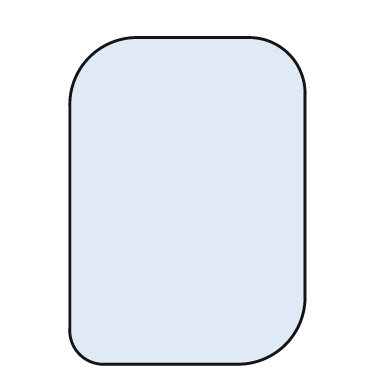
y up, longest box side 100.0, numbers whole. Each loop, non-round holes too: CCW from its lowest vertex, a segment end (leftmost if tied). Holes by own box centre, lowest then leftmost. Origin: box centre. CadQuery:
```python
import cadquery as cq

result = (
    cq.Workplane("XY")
    .moveTo(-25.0, -50.0)
    .lineTo(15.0, -50.0)
    .threePointArc((30.0, -44.0), (36.0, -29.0))
    .lineTo(36.0, 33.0)
    .threePointArc((31.0, 45.0), (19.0, 50.0))
    .lineTo(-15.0, 50.0)
    .threePointArc((-30.0, 44.0), (-36.0, 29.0))
    .lineTo(-36.0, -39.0)
    .threePointArc((-33.0, -47.0), (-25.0, -50.0))
    .close()
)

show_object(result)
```